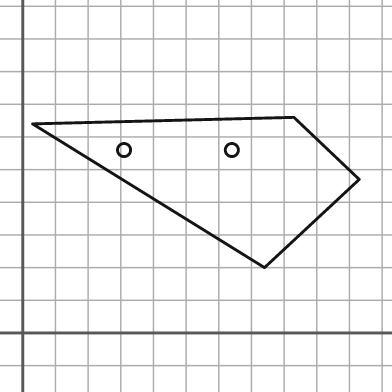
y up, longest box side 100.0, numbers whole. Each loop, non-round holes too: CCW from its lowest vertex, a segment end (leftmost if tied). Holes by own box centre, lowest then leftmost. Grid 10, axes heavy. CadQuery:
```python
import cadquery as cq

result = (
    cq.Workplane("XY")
    .moveTo(74.0, 20.0)
    .lineTo(103.0, 47.0)
    .lineTo(83.0, 66.0)
    .lineTo(3.0, 64.0)
    .close()
    .moveTo(31.0, 56.0)
    .circle(2.0)
    .moveTo(64.0, 56.0)
    .circle(2.0)
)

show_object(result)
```